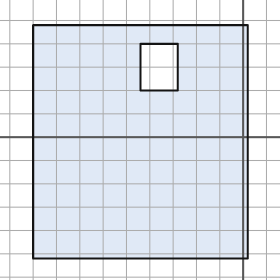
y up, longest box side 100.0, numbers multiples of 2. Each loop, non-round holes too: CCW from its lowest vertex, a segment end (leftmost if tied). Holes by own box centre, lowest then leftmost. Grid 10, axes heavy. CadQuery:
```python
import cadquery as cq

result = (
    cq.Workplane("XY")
    .moveTo(-90.0, -52.0)
    .lineTo(2.0, -52.0)
    .lineTo(2.0, 48.0)
    .lineTo(-90.0, 48.0)
    .close()
    .moveTo(-44.0, 20.0)
    .lineTo(-28.0, 20.0)
    .lineTo(-28.0, 40.0)
    .lineTo(-44.0, 40.0)
    .close()
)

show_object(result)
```